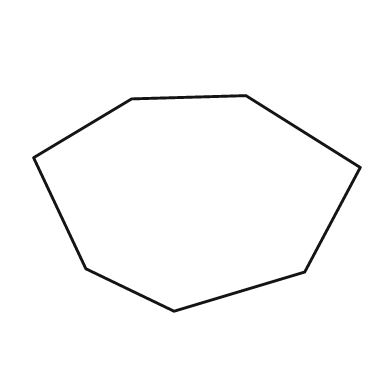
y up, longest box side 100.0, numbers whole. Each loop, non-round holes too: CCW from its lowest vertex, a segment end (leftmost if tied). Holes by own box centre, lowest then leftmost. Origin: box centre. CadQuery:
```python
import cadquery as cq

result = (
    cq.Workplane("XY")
    .moveTo(-7.0, -33.0)
    .lineTo(33.0, -21.0)
    .lineTo(50.0, 11.0)
    .lineTo(15.0, 33.0)
    .lineTo(-20.0, 32.0)
    .lineTo(-50.0, 14.0)
    .lineTo(-34.0, -20.0)
    .close()
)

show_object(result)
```